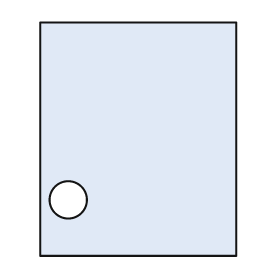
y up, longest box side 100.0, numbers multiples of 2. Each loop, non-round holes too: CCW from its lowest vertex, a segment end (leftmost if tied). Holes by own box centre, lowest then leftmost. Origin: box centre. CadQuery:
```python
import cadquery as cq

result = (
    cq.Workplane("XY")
    .moveTo(-42.0, -50.0)
    .lineTo(42.0, -50.0)
    .lineTo(42.0, 50.0)
    .lineTo(-42.0, 50.0)
    .close()
    .moveTo(-30.0, -26.0)
    .circle(8.0)
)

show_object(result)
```